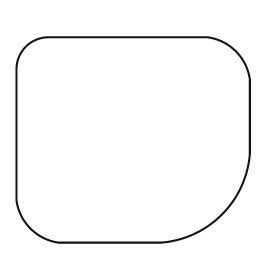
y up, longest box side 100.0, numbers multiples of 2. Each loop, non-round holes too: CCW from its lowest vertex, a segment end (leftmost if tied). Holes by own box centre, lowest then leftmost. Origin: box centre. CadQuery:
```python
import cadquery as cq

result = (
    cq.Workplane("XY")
    .moveTo(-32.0, -44.0)
    .lineTo(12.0, -44.0)
    .threePointArc((38.0, -32.0), (50.0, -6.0))
    .lineTo(50.0, 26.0)
    .threePointArc((44.0, 38.0), (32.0, 44.0))
    .lineTo(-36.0, 44.0)
    .threePointArc((-46.0, 40.0), (-50.0, 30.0))
    .lineTo(-50.0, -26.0)
    .threePointArc((-44.0, -38.0), (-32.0, -44.0))
    .close()
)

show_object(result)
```